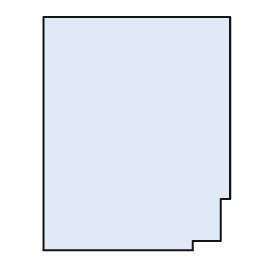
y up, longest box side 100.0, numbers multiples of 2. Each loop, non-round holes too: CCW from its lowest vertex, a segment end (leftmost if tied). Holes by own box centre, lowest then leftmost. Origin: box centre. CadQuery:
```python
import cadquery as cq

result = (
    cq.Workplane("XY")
    .moveTo(-40.0, -50.0)
    .lineTo(24.0, -50.0)
    .lineTo(24.0, -46.0)
    .lineTo(36.0, -46.0)
    .lineTo(36.0, -28.0)
    .lineTo(40.0, -28.0)
    .lineTo(40.0, 50.0)
    .lineTo(-40.0, 50.0)
    .close()
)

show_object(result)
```